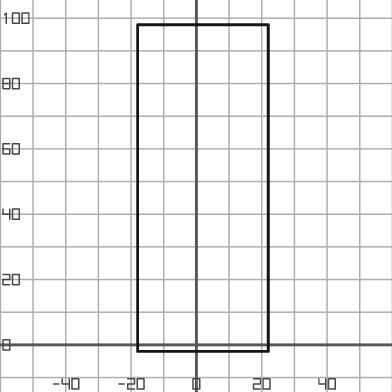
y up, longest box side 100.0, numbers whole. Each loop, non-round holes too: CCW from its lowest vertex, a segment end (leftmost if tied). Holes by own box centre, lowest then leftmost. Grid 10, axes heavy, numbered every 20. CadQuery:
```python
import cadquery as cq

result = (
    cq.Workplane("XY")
    .moveTo(-18.0, -2.0)
    .lineTo(22.0, -2.0)
    .lineTo(22.0, 98.0)
    .lineTo(-18.0, 98.0)
    .close()
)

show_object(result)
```